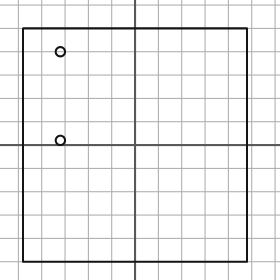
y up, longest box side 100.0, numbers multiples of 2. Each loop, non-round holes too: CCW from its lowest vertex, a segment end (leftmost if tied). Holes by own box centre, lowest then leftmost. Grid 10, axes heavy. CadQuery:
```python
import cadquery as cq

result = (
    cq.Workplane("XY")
    .moveTo(-48.0, -50.0)
    .lineTo(48.0, -50.0)
    .lineTo(48.0, 50.0)
    .lineTo(-48.0, 50.0)
    .close()
    .moveTo(-32.0, 2.0)
    .circle(2.0)
    .moveTo(-32.0, 40.0)
    .circle(2.0)
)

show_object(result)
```